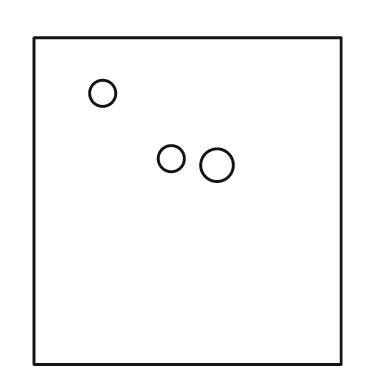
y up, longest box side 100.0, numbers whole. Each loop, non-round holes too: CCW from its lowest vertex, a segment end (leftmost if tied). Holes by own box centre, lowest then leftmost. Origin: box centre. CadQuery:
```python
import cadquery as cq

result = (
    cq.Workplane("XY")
    .moveTo(-47.0, -50.0)
    .lineTo(47.0, -50.0)
    .lineTo(47.0, 50.0)
    .lineTo(-47.0, 50.0)
    .close()
    .moveTo(9.0, 11.0)
    .circle(5.0)
    .moveTo(-5.0, 13.0)
    .circle(4.0)
    .moveTo(-26.0, 33.0)
    .circle(4.0)
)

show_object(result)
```